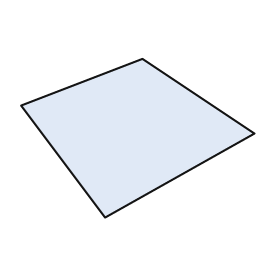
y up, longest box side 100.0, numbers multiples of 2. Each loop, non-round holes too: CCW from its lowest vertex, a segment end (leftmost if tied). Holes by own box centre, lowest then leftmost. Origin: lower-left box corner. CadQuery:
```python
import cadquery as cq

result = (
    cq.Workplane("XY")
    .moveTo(36.0, 0.0)
    .lineTo(100.0, 36.0)
    .lineTo(52.0, 68.0)
    .lineTo(0.0, 48.0)
    .close()
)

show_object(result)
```